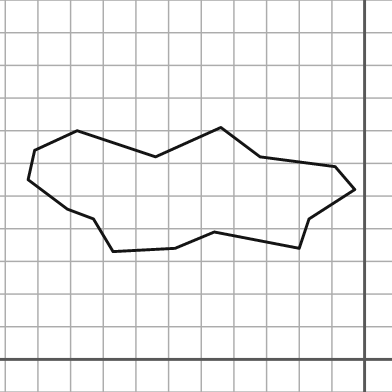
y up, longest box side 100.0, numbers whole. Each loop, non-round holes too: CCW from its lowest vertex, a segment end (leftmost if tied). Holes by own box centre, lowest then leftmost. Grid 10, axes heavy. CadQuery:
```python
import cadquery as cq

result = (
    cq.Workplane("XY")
    .moveTo(-77.0, 33.0)
    .lineTo(-58.0, 34.0)
    .lineTo(-46.0, 39.0)
    .lineTo(-20.0, 34.0)
    .lineTo(-17.0, 43.0)
    .lineTo(-3.0, 52.0)
    .lineTo(-9.0, 59.0)
    .lineTo(-32.0, 62.0)
    .lineTo(-44.0, 71.0)
    .lineTo(-64.0, 62.0)
    .lineTo(-88.0, 70.0)
    .lineTo(-101.0, 64.0)
    .lineTo(-103.0, 55.0)
    .lineTo(-91.0, 46.0)
    .lineTo(-83.0, 43.0)
    .close()
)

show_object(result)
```